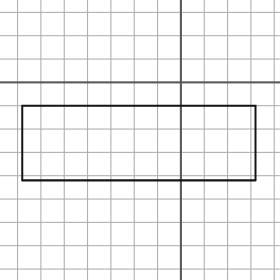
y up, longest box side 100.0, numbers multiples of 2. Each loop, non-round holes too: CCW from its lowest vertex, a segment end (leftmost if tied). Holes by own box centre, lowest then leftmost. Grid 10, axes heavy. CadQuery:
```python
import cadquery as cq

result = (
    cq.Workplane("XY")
    .moveTo(-68.0, -42.0)
    .lineTo(32.0, -42.0)
    .lineTo(32.0, -10.0)
    .lineTo(-68.0, -10.0)
    .close()
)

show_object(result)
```